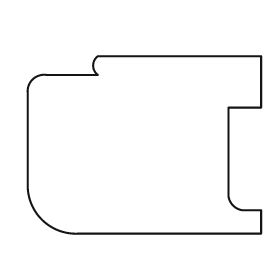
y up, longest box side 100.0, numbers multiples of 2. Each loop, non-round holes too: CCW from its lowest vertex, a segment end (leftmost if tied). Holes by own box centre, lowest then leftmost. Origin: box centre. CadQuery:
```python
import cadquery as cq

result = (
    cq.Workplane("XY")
    .moveTo(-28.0, -38.0)
    .lineTo(50.0, -38.0)
    .lineTo(50.0, -28.0)
    .lineTo(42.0, -28.0)
    .threePointArc((38.0, -26.0), (36.0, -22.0))
    .lineTo(36.0, 16.0)
    .lineTo(50.0, 16.0)
    .lineTo(50.0, 38.0)
    .lineTo(-20.0, 38.0)
    .threePointArc((-22.0, 34.0), (-20.0, 30.0))
    .lineTo(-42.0, 30.0)
    .threePointArc((-48.0, 28.0), (-50.0, 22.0))
    .lineTo(-50.0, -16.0)
    .threePointArc((-44.0, -32.0), (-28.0, -38.0))
    .close()
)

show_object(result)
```